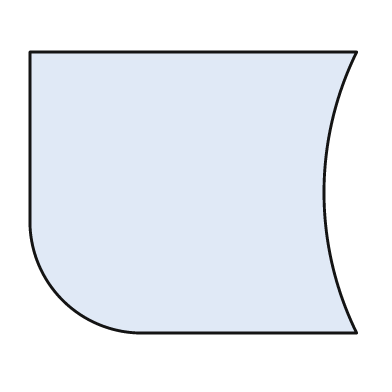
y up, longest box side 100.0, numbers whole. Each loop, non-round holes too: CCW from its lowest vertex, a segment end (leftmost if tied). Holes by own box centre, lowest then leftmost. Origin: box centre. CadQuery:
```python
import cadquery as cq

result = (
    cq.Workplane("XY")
    .moveTo(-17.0, -43.0)
    .lineTo(50.0, -43.0)
    .threePointArc((40.0, 0.0), (50.0, 43.0))
    .lineTo(-50.0, 43.0)
    .lineTo(-50.0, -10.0)
    .threePointArc((-40.0, -33.0), (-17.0, -43.0))
    .close()
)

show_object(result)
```